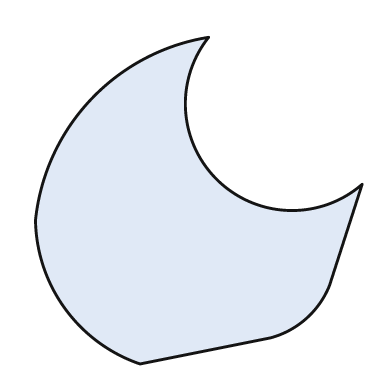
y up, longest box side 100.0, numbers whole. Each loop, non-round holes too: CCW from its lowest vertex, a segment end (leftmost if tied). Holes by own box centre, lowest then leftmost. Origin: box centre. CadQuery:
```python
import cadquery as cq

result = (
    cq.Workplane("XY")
    .moveTo(-18.0, -50.0)
    .lineTo(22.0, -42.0)
    .threePointArc((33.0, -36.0), (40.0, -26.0))
    .lineTo(50.0, 5.0)
    .threePointArc((6.0, 6.0), (3.0, 50.0))
    .threePointArc((-33.0, 31.0), (-50.0, -6.0))
    .threePointArc((-41.0, -33.0), (-18.0, -50.0))
    .close()
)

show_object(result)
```